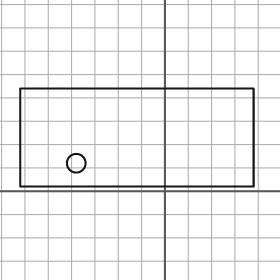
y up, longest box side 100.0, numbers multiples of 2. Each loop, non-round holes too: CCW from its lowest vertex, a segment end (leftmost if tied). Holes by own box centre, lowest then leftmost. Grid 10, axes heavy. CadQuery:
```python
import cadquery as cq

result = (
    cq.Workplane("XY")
    .moveTo(-62.0, 2.0)
    .lineTo(38.0, 2.0)
    .lineTo(38.0, 44.0)
    .lineTo(-62.0, 44.0)
    .close()
    .moveTo(-38.0, 12.0)
    .circle(4.0)
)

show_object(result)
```